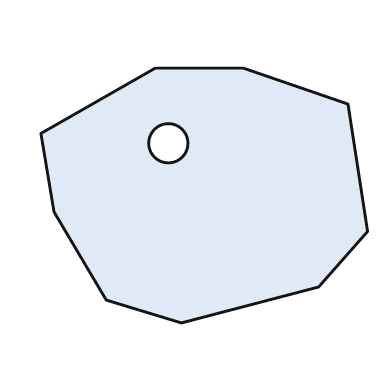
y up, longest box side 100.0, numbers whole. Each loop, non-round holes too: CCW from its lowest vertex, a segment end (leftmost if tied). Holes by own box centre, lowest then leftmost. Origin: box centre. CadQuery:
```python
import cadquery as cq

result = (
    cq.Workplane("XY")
    .moveTo(-7.0, -39.0)
    .lineTo(35.0, -28.0)
    .lineTo(50.0, -11.0)
    .lineTo(44.0, 28.0)
    .lineTo(12.0, 39.0)
    .lineTo(-15.0, 39.0)
    .lineTo(-50.0, 19.0)
    .lineTo(-46.0, -5.0)
    .lineTo(-30.0, -32.0)
    .close()
    .moveTo(-11.0, 16.0)
    .circle(6.0)
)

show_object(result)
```